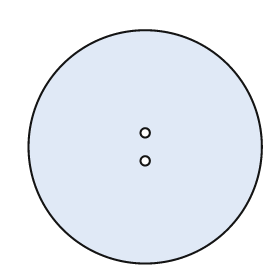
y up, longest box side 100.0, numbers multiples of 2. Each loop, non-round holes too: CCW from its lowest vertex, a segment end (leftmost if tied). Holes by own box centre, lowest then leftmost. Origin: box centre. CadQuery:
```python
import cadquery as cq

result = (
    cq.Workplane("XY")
    .moveTo(0.0, 0.0)
    .circle(50.0)
    .moveTo(0.0, -6.0)
    .circle(2.0)
    .moveTo(0.0, 6.0)
    .circle(2.0)
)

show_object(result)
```